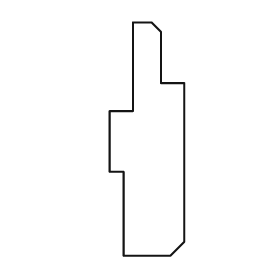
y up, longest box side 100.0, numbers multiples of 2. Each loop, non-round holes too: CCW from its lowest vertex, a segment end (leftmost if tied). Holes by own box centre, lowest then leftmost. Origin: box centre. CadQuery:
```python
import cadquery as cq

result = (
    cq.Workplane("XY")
    .moveTo(-10.0, -50.0)
    .lineTo(10.0, -50.0)
    .lineTo(16.0, -44.0)
    .lineTo(16.0, 24.0)
    .lineTo(6.0, 24.0)
    .lineTo(6.0, 46.0)
    .lineTo(2.0, 50.0)
    .lineTo(-6.0, 50.0)
    .lineTo(-6.0, 12.0)
    .lineTo(-16.0, 12.0)
    .lineTo(-16.0, -14.0)
    .lineTo(-10.0, -14.0)
    .close()
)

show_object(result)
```